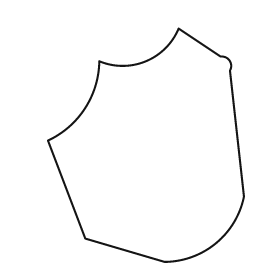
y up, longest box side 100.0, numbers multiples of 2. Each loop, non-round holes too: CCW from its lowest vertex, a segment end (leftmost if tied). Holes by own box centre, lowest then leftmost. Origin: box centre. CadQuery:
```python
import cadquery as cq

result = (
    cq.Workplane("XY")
    .moveTo(8.0, -50.0)
    .threePointArc((30.0, -42.0), (42.0, -22.0))
    .lineTo(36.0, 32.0)
    .threePointArc((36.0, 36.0), (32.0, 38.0))
    .lineTo(14.0, 50.0)
    .threePointArc((0.0, 36.0), (-20.0, 36.0))
    .threePointArc((-26.0, 16.0), (-42.0, 2.0))
    .lineTo(-26.0, -40.0)
    .close()
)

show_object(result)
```